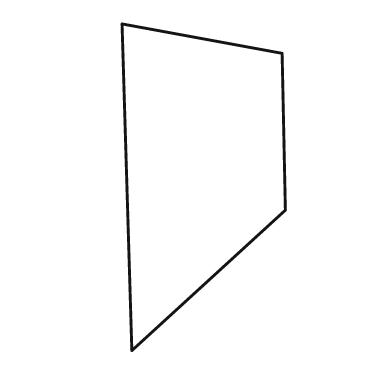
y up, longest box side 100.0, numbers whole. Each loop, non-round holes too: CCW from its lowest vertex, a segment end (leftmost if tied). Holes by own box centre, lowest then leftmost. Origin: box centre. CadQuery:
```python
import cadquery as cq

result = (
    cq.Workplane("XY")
    .moveTo(-22.0, -50.0)
    .lineTo(25.0, -7.0)
    .lineTo(24.0, 41.0)
    .lineTo(-25.0, 50.0)
    .close()
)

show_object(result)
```